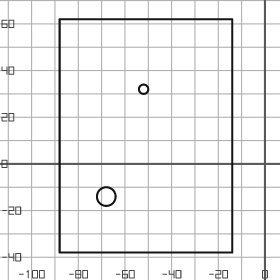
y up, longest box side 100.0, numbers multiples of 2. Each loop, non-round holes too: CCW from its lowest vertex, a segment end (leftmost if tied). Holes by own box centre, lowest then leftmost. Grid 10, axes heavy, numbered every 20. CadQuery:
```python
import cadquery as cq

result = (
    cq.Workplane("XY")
    .moveTo(-88.0, -38.0)
    .lineTo(-14.0, -38.0)
    .lineTo(-14.0, 62.0)
    .lineTo(-88.0, 62.0)
    .close()
    .moveTo(-68.0, -14.0)
    .circle(4.0)
    .moveTo(-52.0, 32.0)
    .circle(2.0)
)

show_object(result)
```